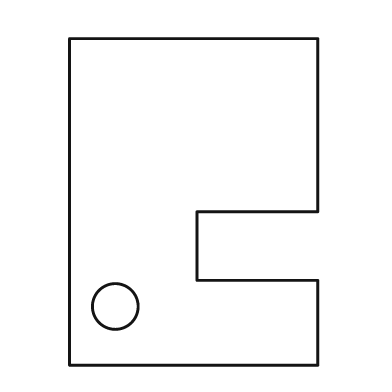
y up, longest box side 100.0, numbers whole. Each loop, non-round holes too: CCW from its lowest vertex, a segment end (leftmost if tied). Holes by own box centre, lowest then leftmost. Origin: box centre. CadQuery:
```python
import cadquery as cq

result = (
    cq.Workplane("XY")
    .moveTo(-38.0, -50.0)
    .lineTo(38.0, -50.0)
    .lineTo(38.0, -24.0)
    .lineTo(1.0, -24.0)
    .lineTo(1.0, -3.0)
    .lineTo(38.0, -3.0)
    .lineTo(38.0, 50.0)
    .lineTo(-38.0, 50.0)
    .close()
    .moveTo(-24.0, -32.0)
    .circle(7.0)
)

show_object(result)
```